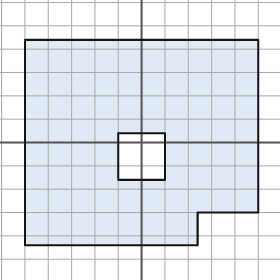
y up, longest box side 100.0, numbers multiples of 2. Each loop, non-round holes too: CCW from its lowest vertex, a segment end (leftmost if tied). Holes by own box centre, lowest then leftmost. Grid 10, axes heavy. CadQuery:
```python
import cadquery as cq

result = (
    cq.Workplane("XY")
    .moveTo(-50.0, -44.0)
    .lineTo(24.0, -44.0)
    .lineTo(24.0, -30.0)
    .lineTo(50.0, -30.0)
    .lineTo(50.0, 44.0)
    .lineTo(-50.0, 44.0)
    .close()
    .moveTo(-10.0, -16.0)
    .lineTo(10.0, -16.0)
    .lineTo(10.0, 4.0)
    .lineTo(-10.0, 4.0)
    .close()
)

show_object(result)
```